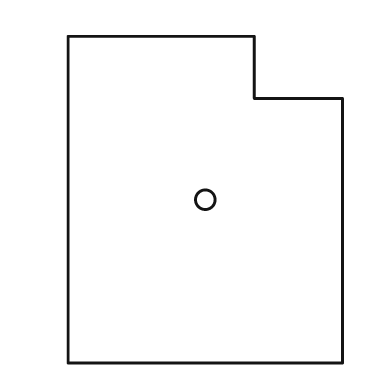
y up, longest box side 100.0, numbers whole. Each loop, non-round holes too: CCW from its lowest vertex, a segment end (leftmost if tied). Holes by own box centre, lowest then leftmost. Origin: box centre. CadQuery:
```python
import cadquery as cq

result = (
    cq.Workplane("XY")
    .moveTo(-42.0, -50.0)
    .lineTo(42.0, -50.0)
    .lineTo(42.0, 31.0)
    .lineTo(15.0, 31.0)
    .lineTo(15.0, 50.0)
    .lineTo(-42.0, 50.0)
    .close()
    .moveTo(0.0, 0.0)
    .circle(3.0)
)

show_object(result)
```